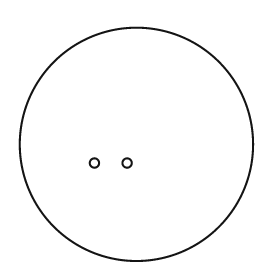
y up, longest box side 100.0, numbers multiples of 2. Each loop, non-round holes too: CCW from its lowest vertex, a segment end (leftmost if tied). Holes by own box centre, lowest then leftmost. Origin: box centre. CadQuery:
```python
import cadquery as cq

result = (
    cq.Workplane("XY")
    .moveTo(0.0, 0.0)
    .circle(50.0)
    .moveTo(-18.0, -8.0)
    .circle(2.0)
    .moveTo(-4.0, -8.0)
    .circle(2.0)
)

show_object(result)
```